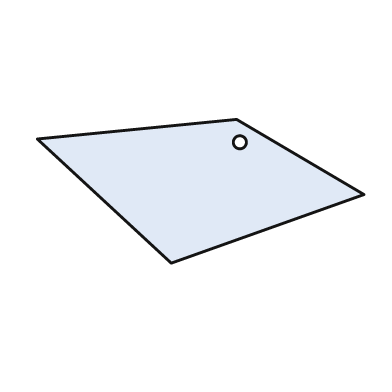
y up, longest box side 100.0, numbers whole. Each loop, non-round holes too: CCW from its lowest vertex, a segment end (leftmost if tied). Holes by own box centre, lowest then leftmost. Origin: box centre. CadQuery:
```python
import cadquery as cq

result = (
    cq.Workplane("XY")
    .moveTo(-9.0, -22.0)
    .lineTo(50.0, -1.0)
    .lineTo(11.0, 22.0)
    .lineTo(-50.0, 16.0)
    .close()
    .moveTo(12.0, 15.0)
    .circle(2.0)
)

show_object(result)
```